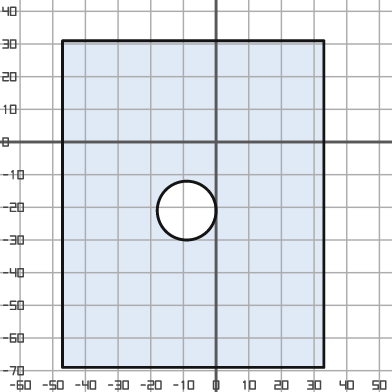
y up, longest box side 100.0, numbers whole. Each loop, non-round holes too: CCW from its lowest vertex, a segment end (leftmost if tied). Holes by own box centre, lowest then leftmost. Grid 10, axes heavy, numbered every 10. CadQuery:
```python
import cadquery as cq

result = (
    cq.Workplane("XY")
    .moveTo(-47.0, -69.0)
    .lineTo(33.0, -69.0)
    .lineTo(33.0, 31.0)
    .lineTo(-47.0, 31.0)
    .close()
    .moveTo(-9.0, -21.0)
    .circle(9.0)
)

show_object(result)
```